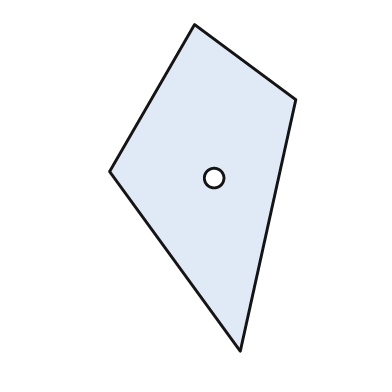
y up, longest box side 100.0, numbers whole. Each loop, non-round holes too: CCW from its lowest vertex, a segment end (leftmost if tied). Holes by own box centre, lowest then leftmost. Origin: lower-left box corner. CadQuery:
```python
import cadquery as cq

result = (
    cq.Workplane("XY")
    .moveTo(40.0, 0.0)
    .lineTo(57.0, 77.0)
    .lineTo(26.0, 100.0)
    .lineTo(0.0, 55.0)
    .close()
    .moveTo(32.0, 53.0)
    .circle(3.0)
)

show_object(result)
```